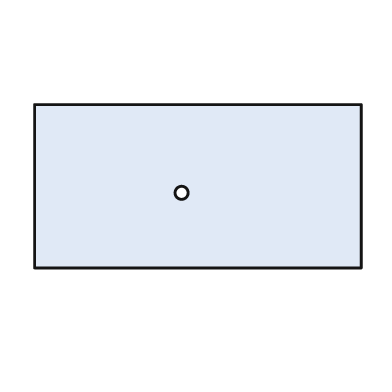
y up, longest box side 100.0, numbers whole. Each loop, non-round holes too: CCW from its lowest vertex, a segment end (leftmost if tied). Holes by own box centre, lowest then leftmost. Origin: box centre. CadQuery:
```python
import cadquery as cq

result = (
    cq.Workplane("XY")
    .moveTo(-50.0, -25.0)
    .lineTo(50.0, -25.0)
    .lineTo(50.0, 25.0)
    .lineTo(-50.0, 25.0)
    .close()
    .moveTo(-5.0, -2.0)
    .circle(2.0)
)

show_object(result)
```